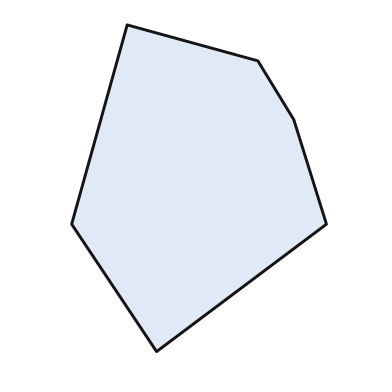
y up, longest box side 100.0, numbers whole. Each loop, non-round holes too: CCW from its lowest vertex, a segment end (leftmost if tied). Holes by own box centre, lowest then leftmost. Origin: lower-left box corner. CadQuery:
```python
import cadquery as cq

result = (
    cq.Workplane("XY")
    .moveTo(26.0, 0.0)
    .lineTo(78.0, 39.0)
    .lineTo(68.0, 71.0)
    .lineTo(57.0, 89.0)
    .lineTo(17.0, 100.0)
    .lineTo(0.0, 39.0)
    .close()
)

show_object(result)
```